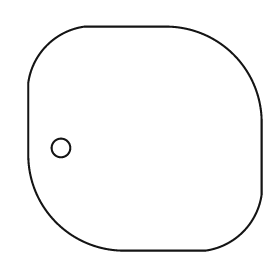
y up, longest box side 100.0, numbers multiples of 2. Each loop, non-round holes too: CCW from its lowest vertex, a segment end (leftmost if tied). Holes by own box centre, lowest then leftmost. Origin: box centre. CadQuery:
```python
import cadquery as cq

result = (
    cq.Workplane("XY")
    .moveTo(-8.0, -48.0)
    .lineTo(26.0, -48.0)
    .threePointArc((42.0, -40.0), (50.0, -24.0))
    .lineTo(50.0, 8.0)
    .threePointArc((38.0, 36.0), (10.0, 48.0))
    .lineTo(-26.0, 48.0)
    .threePointArc((-42.0, 40.0), (-50.0, 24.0))
    .lineTo(-50.0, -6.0)
    .threePointArc((-38.0, -36.0), (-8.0, -48.0))
    .close()
    .moveTo(-36.0, -4.0)
    .circle(4.0)
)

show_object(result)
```